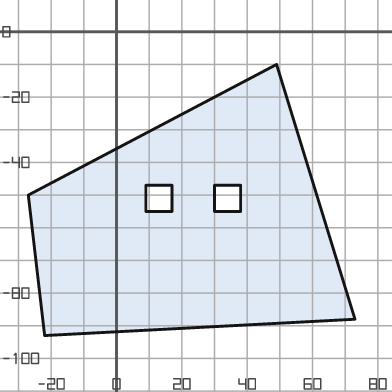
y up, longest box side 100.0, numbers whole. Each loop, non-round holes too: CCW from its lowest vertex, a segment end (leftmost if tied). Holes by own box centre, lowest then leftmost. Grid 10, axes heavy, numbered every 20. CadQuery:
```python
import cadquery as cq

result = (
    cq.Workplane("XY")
    .moveTo(-22.0, -93.0)
    .lineTo(73.0, -88.0)
    .lineTo(49.0, -10.0)
    .lineTo(-27.0, -50.0)
    .close()
    .moveTo(9.0, -55.0)
    .lineTo(17.0, -55.0)
    .lineTo(17.0, -47.0)
    .lineTo(9.0, -47.0)
    .close()
    .moveTo(30.0, -55.0)
    .lineTo(38.0, -55.0)
    .lineTo(38.0, -47.0)
    .lineTo(30.0, -47.0)
    .close()
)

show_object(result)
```